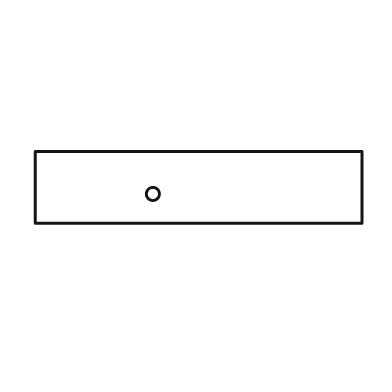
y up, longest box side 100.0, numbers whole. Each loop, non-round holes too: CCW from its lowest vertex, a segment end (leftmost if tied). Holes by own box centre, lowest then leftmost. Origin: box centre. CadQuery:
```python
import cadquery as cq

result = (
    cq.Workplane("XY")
    .moveTo(-50.0, -11.0)
    .lineTo(50.0, -11.0)
    .lineTo(50.0, 11.0)
    .lineTo(-50.0, 11.0)
    .close()
    .moveTo(-14.0, -2.0)
    .circle(2.0)
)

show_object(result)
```